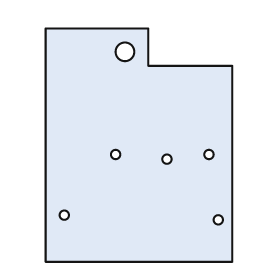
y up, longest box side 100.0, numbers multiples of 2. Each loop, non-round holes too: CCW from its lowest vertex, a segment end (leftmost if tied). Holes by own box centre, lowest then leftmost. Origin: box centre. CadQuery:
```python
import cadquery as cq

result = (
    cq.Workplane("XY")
    .moveTo(-40.0, -50.0)
    .lineTo(40.0, -50.0)
    .lineTo(40.0, 34.0)
    .lineTo(4.0, 34.0)
    .lineTo(4.0, 50.0)
    .lineTo(-40.0, 50.0)
    .close()
    .moveTo(34.0, -32.0)
    .circle(2.0)
    .moveTo(-32.0, -30.0)
    .circle(2.0)
    .moveTo(12.0, -6.0)
    .circle(2.0)
    .moveTo(-10.0, -4.0)
    .circle(2.0)
    .moveTo(30.0, -4.0)
    .circle(2.0)
    .moveTo(-6.0, 40.0)
    .circle(4.0)
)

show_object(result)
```